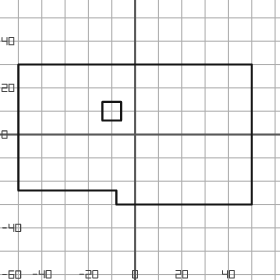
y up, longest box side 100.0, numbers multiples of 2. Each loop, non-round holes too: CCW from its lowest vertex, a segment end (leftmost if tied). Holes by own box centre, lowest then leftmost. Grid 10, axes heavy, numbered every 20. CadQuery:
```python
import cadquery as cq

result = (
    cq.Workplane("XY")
    .moveTo(-8.0, -30.0)
    .lineTo(50.0, -30.0)
    .lineTo(50.0, 30.0)
    .lineTo(-50.0, 30.0)
    .lineTo(-50.0, -24.0)
    .lineTo(-8.0, -24.0)
    .close()
    .moveTo(-14.0, 6.0)
    .lineTo(-6.0, 6.0)
    .lineTo(-6.0, 14.0)
    .lineTo(-14.0, 14.0)
    .close()
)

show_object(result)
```